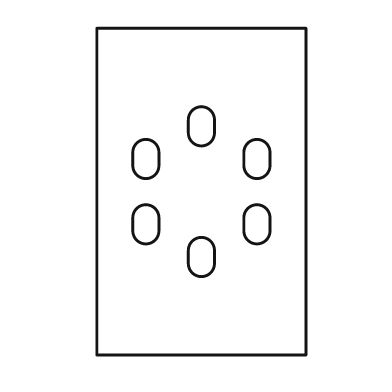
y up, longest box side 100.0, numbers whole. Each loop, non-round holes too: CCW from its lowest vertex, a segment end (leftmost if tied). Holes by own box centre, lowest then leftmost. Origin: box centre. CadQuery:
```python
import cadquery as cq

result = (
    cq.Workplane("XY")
    .moveTo(-32.0, -50.0)
    .lineTo(32.0, -50.0)
    .lineTo(32.0, 50.0)
    .lineTo(-32.0, 50.0)
    .close()
    .moveTo(-4.0, -22.0)
    .threePointArc((0.0, -26.0), (4.0, -22.0))
    .lineTo(4.0, -18.0)
    .threePointArc((0.0, -14.0), (-4.0, -18.0))
    .close()
    .moveTo(-21.0, -12.0)
    .threePointArc((-17.0, -16.0), (-13.0, -12.0))
    .lineTo(-13.0, -8.0)
    .threePointArc((-17.0, -4.0), (-21.0, -8.0))
    .close()
    .moveTo(13.0, -12.0)
    .threePointArc((17.0, -16.0), (21.0, -12.0))
    .lineTo(21.0, -8.0)
    .threePointArc((17.0, -4.0), (13.0, -8.0))
    .close()
    .moveTo(-21.0, 8.0)
    .threePointArc((-17.0, 4.0), (-13.0, 8.0))
    .lineTo(-13.0, 12.0)
    .threePointArc((-17.0, 16.0), (-21.0, 12.0))
    .close()
    .moveTo(13.0, 8.0)
    .threePointArc((17.0, 4.0), (21.0, 8.0))
    .lineTo(21.0, 12.0)
    .threePointArc((17.0, 16.0), (13.0, 12.0))
    .close()
    .moveTo(-4.0, 18.0)
    .threePointArc((0.0, 14.0), (4.0, 18.0))
    .lineTo(4.0, 22.0)
    .threePointArc((0.0, 26.0), (-4.0, 22.0))
    .close()
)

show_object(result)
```